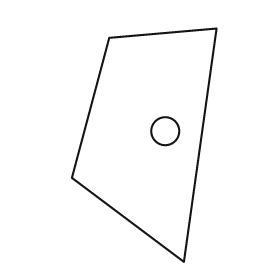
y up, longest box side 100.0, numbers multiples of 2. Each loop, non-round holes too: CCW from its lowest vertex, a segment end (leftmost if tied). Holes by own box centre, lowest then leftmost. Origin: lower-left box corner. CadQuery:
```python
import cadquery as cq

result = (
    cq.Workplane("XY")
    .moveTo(48.0, 0.0)
    .lineTo(62.0, 100.0)
    .lineTo(16.0, 96.0)
    .lineTo(0.0, 36.0)
    .close()
    .moveTo(40.0, 56.0)
    .circle(6.0)
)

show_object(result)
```